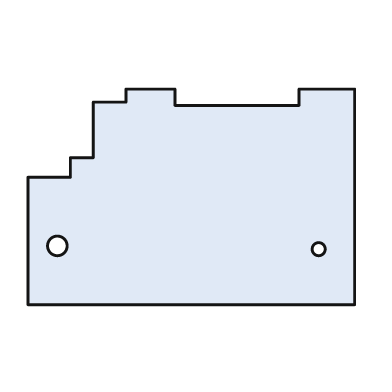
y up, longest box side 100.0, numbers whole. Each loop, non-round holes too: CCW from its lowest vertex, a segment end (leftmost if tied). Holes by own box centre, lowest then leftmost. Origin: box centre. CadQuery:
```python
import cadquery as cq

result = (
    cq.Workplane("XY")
    .moveTo(-50.0, -33.0)
    .lineTo(50.0, -33.0)
    .lineTo(50.0, 33.0)
    .lineTo(33.0, 33.0)
    .lineTo(33.0, 28.0)
    .lineTo(-5.0, 28.0)
    .lineTo(-5.0, 33.0)
    .lineTo(-20.0, 33.0)
    .lineTo(-20.0, 29.0)
    .lineTo(-30.0, 29.0)
    .lineTo(-30.0, 12.0)
    .lineTo(-37.0, 12.0)
    .lineTo(-37.0, 6.0)
    .lineTo(-50.0, 6.0)
    .close()
    .moveTo(39.0, -16.0)
    .circle(2.0)
    .moveTo(-41.0, -15.0)
    .circle(3.0)
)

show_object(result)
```